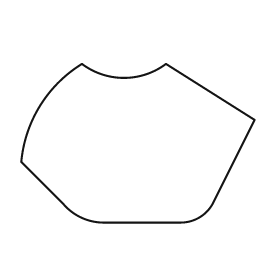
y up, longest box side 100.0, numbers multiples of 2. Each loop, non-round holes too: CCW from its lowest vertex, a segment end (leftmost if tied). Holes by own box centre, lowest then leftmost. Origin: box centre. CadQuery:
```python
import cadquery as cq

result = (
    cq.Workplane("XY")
    .moveTo(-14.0, -34.0)
    .lineTo(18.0, -34.0)
    .threePointArc((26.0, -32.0), (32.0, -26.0))
    .lineTo(50.0, 10.0)
    .lineTo(12.0, 34.0)
    .threePointArc((-6.0, 28.0), (-24.0, 34.0))
    .threePointArc((-42.0, 16.0), (-50.0, -8.0))
    .lineTo(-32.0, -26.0)
    .threePointArc((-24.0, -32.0), (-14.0, -34.0))
    .close()
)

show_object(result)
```